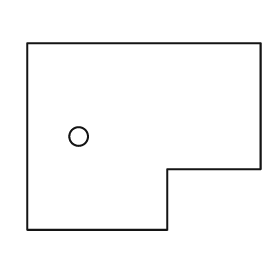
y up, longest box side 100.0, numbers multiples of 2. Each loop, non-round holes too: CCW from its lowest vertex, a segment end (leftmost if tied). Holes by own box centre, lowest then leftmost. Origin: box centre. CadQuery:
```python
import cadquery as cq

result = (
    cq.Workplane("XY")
    .moveTo(-50.0, -40.0)
    .lineTo(10.0, -40.0)
    .lineTo(10.0, -14.0)
    .lineTo(50.0, -14.0)
    .lineTo(50.0, 40.0)
    .lineTo(-50.0, 40.0)
    .close()
    .moveTo(-28.0, 0.0)
    .circle(4.0)
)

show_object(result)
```